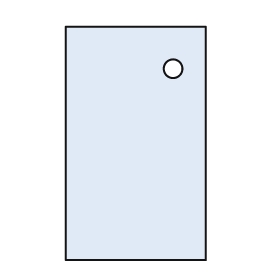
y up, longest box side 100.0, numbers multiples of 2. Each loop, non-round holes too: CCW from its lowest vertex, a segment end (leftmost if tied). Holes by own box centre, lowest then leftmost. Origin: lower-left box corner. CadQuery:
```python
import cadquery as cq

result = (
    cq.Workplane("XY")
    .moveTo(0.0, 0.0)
    .lineTo(60.0, 0.0)
    .lineTo(60.0, 100.0)
    .lineTo(0.0, 100.0)
    .close()
    .moveTo(46.0, 82.0)
    .circle(4.0)
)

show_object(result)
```